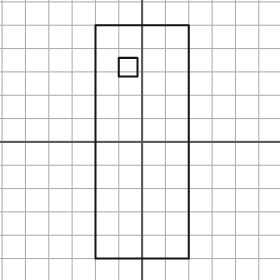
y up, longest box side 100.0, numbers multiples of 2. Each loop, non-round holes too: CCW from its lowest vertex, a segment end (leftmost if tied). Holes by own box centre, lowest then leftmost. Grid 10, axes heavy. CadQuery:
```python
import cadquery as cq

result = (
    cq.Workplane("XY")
    .moveTo(-20.0, -50.0)
    .lineTo(20.0, -50.0)
    .lineTo(20.0, 50.0)
    .lineTo(-20.0, 50.0)
    .close()
    .moveTo(-10.0, 28.0)
    .lineTo(-2.0, 28.0)
    .lineTo(-2.0, 36.0)
    .lineTo(-10.0, 36.0)
    .close()
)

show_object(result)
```